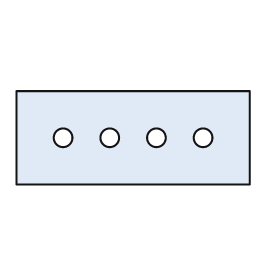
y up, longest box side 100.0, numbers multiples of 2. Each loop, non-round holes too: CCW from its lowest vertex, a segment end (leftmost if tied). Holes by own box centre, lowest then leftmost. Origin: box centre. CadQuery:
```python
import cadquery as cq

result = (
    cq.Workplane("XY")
    .moveTo(-50.0, -20.0)
    .lineTo(50.0, -20.0)
    .lineTo(50.0, 20.0)
    .lineTo(-50.0, 20.0)
    .close()
    .moveTo(-30.0, 0.0)
    .circle(4.0)
    .moveTo(-10.0, 0.0)
    .circle(4.0)
    .moveTo(10.0, 0.0)
    .circle(4.0)
    .moveTo(30.0, 0.0)
    .circle(4.0)
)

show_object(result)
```